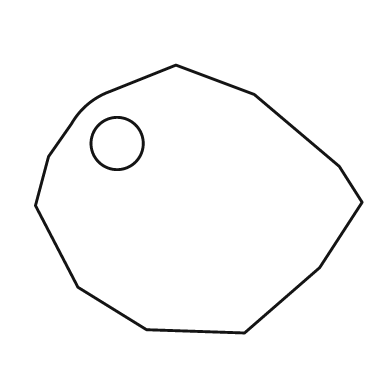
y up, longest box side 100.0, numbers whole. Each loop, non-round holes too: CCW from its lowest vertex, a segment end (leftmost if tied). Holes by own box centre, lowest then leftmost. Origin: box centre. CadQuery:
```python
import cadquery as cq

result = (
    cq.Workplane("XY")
    .moveTo(14.0, -41.0)
    .lineTo(37.0, -21.0)
    .lineTo(50.0, -1.0)
    .lineTo(43.0, 10.0)
    .lineTo(17.0, 32.0)
    .lineTo(-7.0, 41.0)
    .lineTo(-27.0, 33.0)
    .threePointArc((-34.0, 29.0), (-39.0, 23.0))
    .lineTo(-46.0, 13.0)
    .lineTo(-50.0, -2.0)
    .lineTo(-37.0, -27.0)
    .lineTo(-16.0, -40.0)
    .close()
    .moveTo(-25.0, 17.0)
    .circle(8.0)
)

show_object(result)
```